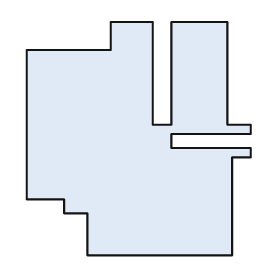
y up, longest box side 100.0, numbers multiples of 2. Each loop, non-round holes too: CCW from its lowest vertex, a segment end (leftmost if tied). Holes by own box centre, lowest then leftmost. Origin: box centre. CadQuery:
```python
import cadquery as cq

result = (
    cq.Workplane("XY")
    .moveTo(-22.0, -50.0)
    .lineTo(40.0, -50.0)
    .lineTo(40.0, -8.0)
    .lineTo(48.0, -8.0)
    .lineTo(48.0, -4.0)
    .lineTo(14.0, -4.0)
    .lineTo(14.0, 2.0)
    .lineTo(48.0, 2.0)
    .lineTo(48.0, 6.0)
    .lineTo(38.0, 6.0)
    .lineTo(38.0, 50.0)
    .lineTo(14.0, 50.0)
    .lineTo(14.0, 6.0)
    .lineTo(6.0, 6.0)
    .lineTo(6.0, 50.0)
    .lineTo(-12.0, 50.0)
    .lineTo(-12.0, 38.0)
    .lineTo(-48.0, 38.0)
    .lineTo(-48.0, -26.0)
    .lineTo(-32.0, -26.0)
    .lineTo(-32.0, -32.0)
    .lineTo(-22.0, -32.0)
    .close()
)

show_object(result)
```